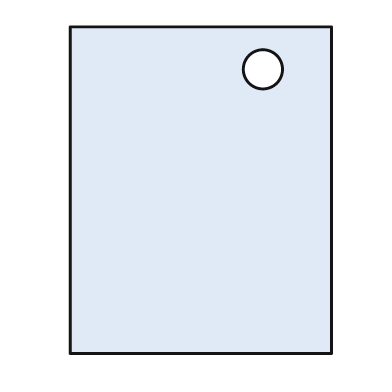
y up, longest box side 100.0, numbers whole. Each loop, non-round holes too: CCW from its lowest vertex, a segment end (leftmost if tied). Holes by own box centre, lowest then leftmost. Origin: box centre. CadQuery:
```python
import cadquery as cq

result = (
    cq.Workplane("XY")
    .moveTo(-40.0, -50.0)
    .lineTo(40.0, -50.0)
    .lineTo(40.0, 50.0)
    .lineTo(-40.0, 50.0)
    .close()
    .moveTo(19.0, 37.0)
    .circle(6.0)
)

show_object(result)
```